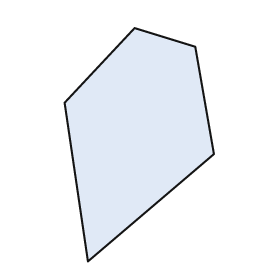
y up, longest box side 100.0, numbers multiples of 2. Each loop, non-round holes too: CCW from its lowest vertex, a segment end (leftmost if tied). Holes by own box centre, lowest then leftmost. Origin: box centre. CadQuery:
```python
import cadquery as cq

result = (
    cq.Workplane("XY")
    .moveTo(-22.0, -50.0)
    .lineTo(32.0, -4.0)
    .lineTo(24.0, 42.0)
    .lineTo(-2.0, 50.0)
    .lineTo(-32.0, 18.0)
    .close()
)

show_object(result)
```